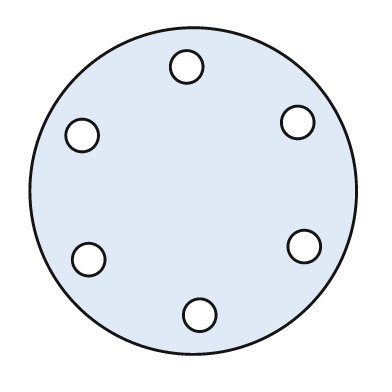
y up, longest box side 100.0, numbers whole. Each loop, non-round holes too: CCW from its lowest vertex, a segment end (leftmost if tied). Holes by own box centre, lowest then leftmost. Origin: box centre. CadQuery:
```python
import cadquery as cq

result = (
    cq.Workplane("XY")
    .moveTo(0.0, 0.0)
    .circle(50.0)
    .moveTo(2.0, -38.0)
    .circle(5.0)
    .moveTo(-32.0, -21.0)
    .circle(5.0)
    .moveTo(34.0, -17.0)
    .circle(5.0)
    .moveTo(-34.0, 17.0)
    .circle(5.0)
    .moveTo(32.0, 21.0)
    .circle(5.0)
    .moveTo(-2.0, 38.0)
    .circle(5.0)
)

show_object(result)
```